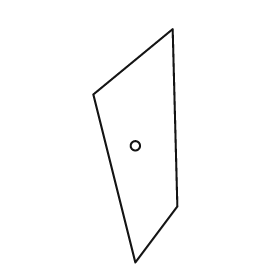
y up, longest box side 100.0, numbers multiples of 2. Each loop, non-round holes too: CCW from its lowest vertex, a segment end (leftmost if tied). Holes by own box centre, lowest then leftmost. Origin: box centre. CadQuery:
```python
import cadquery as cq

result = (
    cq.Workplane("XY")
    .moveTo(0.0, -50.0)
    .lineTo(18.0, -26.0)
    .lineTo(16.0, 50.0)
    .lineTo(-18.0, 22.0)
    .close()
    .moveTo(0.0, 0.0)
    .circle(2.0)
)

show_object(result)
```